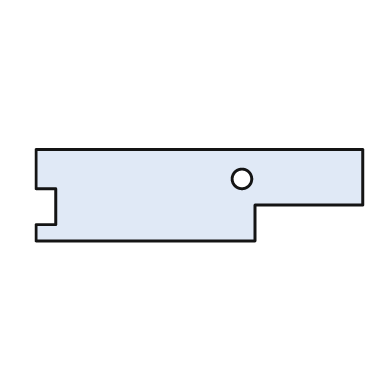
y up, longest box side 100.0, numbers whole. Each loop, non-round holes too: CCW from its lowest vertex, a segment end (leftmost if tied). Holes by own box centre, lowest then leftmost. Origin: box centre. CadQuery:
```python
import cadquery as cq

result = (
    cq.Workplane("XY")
    .moveTo(-50.0, -14.0)
    .lineTo(17.0, -14.0)
    .lineTo(17.0, -3.0)
    .lineTo(50.0, -3.0)
    .lineTo(50.0, 14.0)
    .lineTo(-50.0, 14.0)
    .lineTo(-50.0, 2.0)
    .lineTo(-44.0, 2.0)
    .lineTo(-44.0, -9.0)
    .lineTo(-50.0, -9.0)
    .close()
    .moveTo(13.0, 5.0)
    .circle(3.0)
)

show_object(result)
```